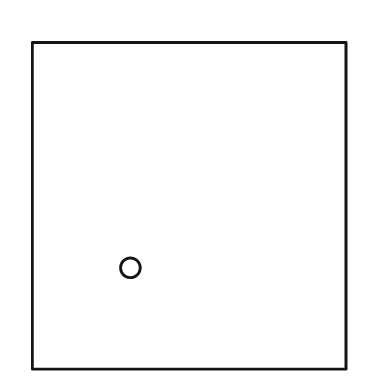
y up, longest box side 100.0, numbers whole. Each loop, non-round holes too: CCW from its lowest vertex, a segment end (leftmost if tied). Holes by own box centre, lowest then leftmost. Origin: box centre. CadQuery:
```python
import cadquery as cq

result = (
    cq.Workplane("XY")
    .moveTo(-48.0, -50.0)
    .lineTo(48.0, -50.0)
    .lineTo(48.0, 50.0)
    .lineTo(-48.0, 50.0)
    .close()
    .moveTo(-18.0, -19.0)
    .circle(3.0)
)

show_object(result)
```